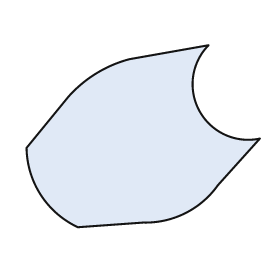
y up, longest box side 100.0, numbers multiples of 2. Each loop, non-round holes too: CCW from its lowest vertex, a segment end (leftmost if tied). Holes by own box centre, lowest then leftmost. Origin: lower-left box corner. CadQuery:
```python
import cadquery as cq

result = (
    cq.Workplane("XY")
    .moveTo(22.0, 0.0)
    .lineTo(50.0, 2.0)
    .threePointArc((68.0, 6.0), (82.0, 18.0))
    .lineTo(100.0, 38.0)
    .threePointArc((74.0, 50.0), (78.0, 78.0))
    .lineTo(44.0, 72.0)
    .threePointArc((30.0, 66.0), (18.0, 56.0))
    .lineTo(0.0, 34.0)
    .threePointArc((6.0, 14.0), (22.0, 0.0))
    .close()
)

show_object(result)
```